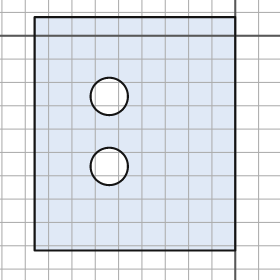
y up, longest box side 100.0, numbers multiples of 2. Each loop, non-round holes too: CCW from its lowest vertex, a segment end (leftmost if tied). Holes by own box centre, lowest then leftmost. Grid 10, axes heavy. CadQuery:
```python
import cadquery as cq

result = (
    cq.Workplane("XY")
    .moveTo(-86.0, -92.0)
    .lineTo(0.0, -92.0)
    .lineTo(0.0, 8.0)
    .lineTo(-86.0, 8.0)
    .close()
    .moveTo(-54.0, -56.0)
    .circle(8.0)
    .moveTo(-54.0, -26.0)
    .circle(8.0)
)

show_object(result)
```